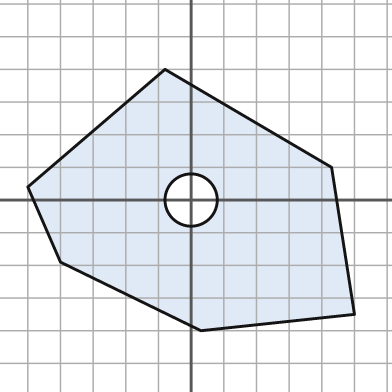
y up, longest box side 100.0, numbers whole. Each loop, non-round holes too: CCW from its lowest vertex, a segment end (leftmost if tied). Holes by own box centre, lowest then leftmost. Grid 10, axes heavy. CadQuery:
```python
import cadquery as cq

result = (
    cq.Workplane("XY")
    .moveTo(3.0, -40.0)
    .lineTo(50.0, -35.0)
    .lineTo(43.0, 10.0)
    .lineTo(-8.0, 40.0)
    .lineTo(-50.0, 4.0)
    .lineTo(-40.0, -19.0)
    .close()
    .moveTo(0.0, 0.0)
    .circle(8.0)
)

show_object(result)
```